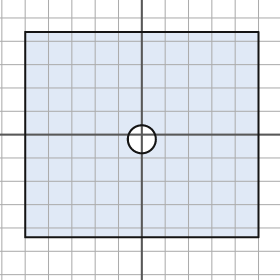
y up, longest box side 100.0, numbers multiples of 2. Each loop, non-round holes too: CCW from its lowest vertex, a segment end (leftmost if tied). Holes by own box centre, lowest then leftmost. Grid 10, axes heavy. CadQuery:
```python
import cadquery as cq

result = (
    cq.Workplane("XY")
    .moveTo(-50.0, -44.0)
    .lineTo(50.0, -44.0)
    .lineTo(50.0, 44.0)
    .lineTo(-50.0, 44.0)
    .close()
    .moveTo(0.0, -2.0)
    .circle(6.0)
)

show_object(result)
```